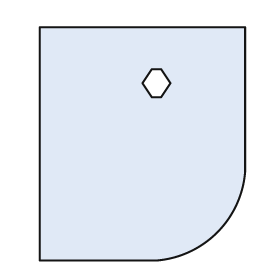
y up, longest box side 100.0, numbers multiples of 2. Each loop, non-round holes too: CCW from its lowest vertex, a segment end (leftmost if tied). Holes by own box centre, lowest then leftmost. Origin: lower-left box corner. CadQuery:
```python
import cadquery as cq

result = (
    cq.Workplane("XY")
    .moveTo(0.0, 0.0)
    .lineTo(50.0, 0.0)
    .threePointArc((76.0, 12.0), (88.0, 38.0))
    .lineTo(88.0, 100.0)
    .lineTo(0.0, 100.0)
    .close()
    .moveTo(48.0, 70.0)
    .lineTo(52.0, 70.0)
    .lineTo(56.0, 76.0)
    .lineTo(52.0, 82.0)
    .lineTo(48.0, 82.0)
    .lineTo(44.0, 76.0)
    .close()
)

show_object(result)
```